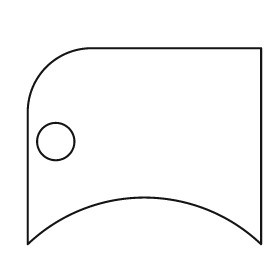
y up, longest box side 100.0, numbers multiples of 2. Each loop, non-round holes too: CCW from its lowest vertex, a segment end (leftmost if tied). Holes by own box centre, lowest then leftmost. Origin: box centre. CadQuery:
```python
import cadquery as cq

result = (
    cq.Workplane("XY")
    .moveTo(-50.0, -42.0)
    .threePointArc((0.0, -22.0), (50.0, -42.0))
    .lineTo(50.0, 42.0)
    .lineTo(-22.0, 42.0)
    .threePointArc((-42.0, 34.0), (-50.0, 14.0))
    .close()
    .moveTo(-38.0, 2.0)
    .circle(8.0)
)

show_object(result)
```